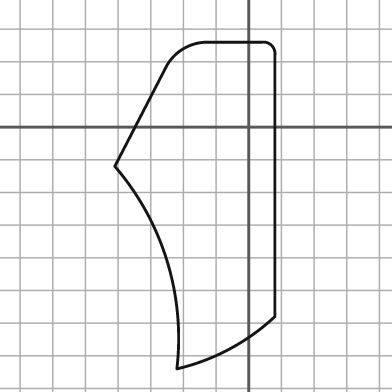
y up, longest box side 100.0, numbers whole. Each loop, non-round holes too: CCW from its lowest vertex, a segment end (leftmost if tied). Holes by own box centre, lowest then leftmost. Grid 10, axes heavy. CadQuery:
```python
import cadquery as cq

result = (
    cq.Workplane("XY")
    .moveTo(-22.0, -74.0)
    .threePointArc((-6.0, -68.0), (8.0, -58.0))
    .lineTo(8.0, 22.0)
    .threePointArc((7.0, 25.0), (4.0, 26.0))
    .lineTo(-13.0, 26.0)
    .threePointArc((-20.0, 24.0), (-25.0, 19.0))
    .lineTo(-41.0, -12.0)
    .threePointArc((-25.0, -41.0), (-22.0, -74.0))
    .close()
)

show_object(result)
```